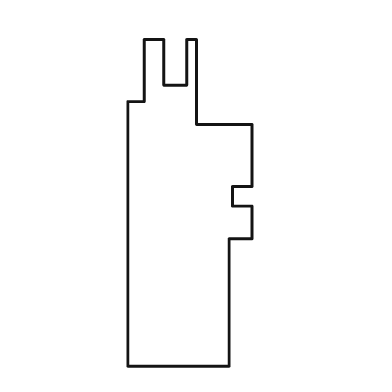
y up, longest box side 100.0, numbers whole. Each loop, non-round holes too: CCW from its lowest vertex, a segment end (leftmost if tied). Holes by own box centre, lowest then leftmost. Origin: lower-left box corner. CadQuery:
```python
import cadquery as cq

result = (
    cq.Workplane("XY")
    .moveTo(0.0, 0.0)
    .lineTo(31.0, 0.0)
    .lineTo(31.0, 39.0)
    .lineTo(38.0, 39.0)
    .lineTo(38.0, 49.0)
    .lineTo(32.0, 49.0)
    .lineTo(32.0, 55.0)
    .lineTo(38.0, 55.0)
    .lineTo(38.0, 74.0)
    .lineTo(21.0, 74.0)
    .lineTo(21.0, 100.0)
    .lineTo(18.0, 100.0)
    .lineTo(18.0, 86.0)
    .lineTo(11.0, 86.0)
    .lineTo(11.0, 100.0)
    .lineTo(5.0, 100.0)
    .lineTo(5.0, 81.0)
    .lineTo(0.0, 81.0)
    .close()
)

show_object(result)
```